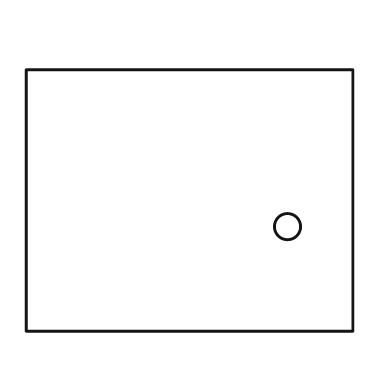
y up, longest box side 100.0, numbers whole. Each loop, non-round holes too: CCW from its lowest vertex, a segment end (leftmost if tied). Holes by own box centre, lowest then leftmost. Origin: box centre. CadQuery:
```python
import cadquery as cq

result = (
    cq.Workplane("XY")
    .moveTo(-50.0, -40.0)
    .lineTo(50.0, -40.0)
    .lineTo(50.0, 40.0)
    .lineTo(-50.0, 40.0)
    .close()
    .moveTo(30.0, -8.0)
    .circle(4.0)
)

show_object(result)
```